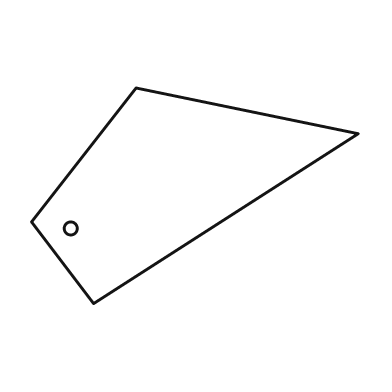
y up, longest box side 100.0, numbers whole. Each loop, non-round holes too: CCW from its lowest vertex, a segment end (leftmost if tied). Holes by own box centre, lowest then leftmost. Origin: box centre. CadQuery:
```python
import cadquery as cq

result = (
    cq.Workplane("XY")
    .moveTo(-31.0, -33.0)
    .lineTo(50.0, 19.0)
    .lineTo(-18.0, 33.0)
    .lineTo(-50.0, -8.0)
    .close()
    .moveTo(-38.0, -10.0)
    .circle(2.0)
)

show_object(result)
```